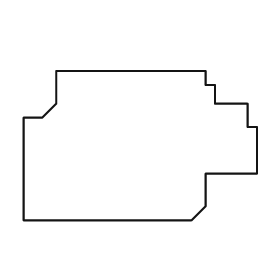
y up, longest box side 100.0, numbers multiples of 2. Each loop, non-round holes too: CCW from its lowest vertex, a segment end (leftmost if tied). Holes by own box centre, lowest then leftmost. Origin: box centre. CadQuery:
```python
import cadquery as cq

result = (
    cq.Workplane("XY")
    .moveTo(-50.0, -32.0)
    .lineTo(22.0, -32.0)
    .lineTo(28.0, -26.0)
    .lineTo(28.0, -12.0)
    .lineTo(50.0, -12.0)
    .lineTo(50.0, 8.0)
    .lineTo(46.0, 8.0)
    .lineTo(46.0, 18.0)
    .lineTo(32.0, 18.0)
    .lineTo(32.0, 26.0)
    .lineTo(28.0, 26.0)
    .lineTo(28.0, 32.0)
    .lineTo(-36.0, 32.0)
    .lineTo(-36.0, 18.0)
    .lineTo(-42.0, 12.0)
    .lineTo(-50.0, 12.0)
    .close()
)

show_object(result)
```